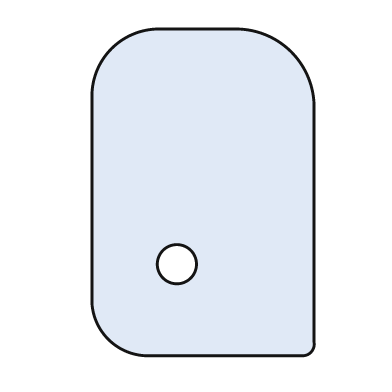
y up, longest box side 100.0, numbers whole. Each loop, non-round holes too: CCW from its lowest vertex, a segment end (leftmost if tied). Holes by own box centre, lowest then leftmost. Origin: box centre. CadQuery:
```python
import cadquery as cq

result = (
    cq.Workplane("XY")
    .moveTo(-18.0, -50.0)
    .lineTo(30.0, -50.0)
    .threePointArc((33.0, -49.0), (34.0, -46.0))
    .lineTo(34.0, 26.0)
    .threePointArc((27.0, 43.0), (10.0, 50.0))
    .lineTo(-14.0, 50.0)
    .threePointArc((-28.0, 44.0), (-34.0, 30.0))
    .lineTo(-34.0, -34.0)
    .threePointArc((-29.0, -45.0), (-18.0, -50.0))
    .close()
    .moveTo(-8.0, -22.0)
    .circle(6.0)
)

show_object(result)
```